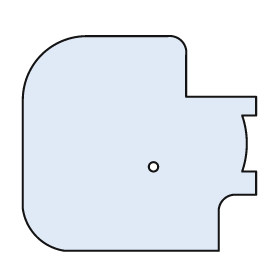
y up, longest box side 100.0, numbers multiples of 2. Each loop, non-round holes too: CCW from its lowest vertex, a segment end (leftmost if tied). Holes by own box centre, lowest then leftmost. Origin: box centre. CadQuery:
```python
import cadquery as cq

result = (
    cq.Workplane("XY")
    .moveTo(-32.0, -46.0)
    .lineTo(34.0, -46.0)
    .lineTo(34.0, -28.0)
    .threePointArc((36.0, -24.0), (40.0, -22.0))
    .lineTo(50.0, -22.0)
    .lineTo(50.0, -12.0)
    .lineTo(44.0, -12.0)
    .threePointArc((46.0, 0.0), (44.0, 12.0))
    .lineTo(50.0, 12.0)
    .lineTo(50.0, 20.0)
    .lineTo(20.0, 20.0)
    .lineTo(20.0, 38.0)
    .threePointArc((18.0, 44.0), (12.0, 46.0))
    .lineTo(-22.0, 46.0)
    .threePointArc((-42.0, 38.0), (-50.0, 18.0))
    .lineTo(-50.0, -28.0)
    .threePointArc((-44.0, -40.0), (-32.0, -46.0))
    .close()
    .moveTo(6.0, -10.0)
    .circle(2.0)
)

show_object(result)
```